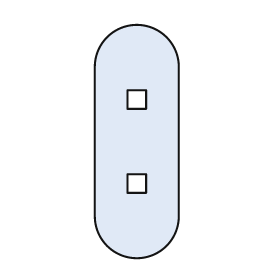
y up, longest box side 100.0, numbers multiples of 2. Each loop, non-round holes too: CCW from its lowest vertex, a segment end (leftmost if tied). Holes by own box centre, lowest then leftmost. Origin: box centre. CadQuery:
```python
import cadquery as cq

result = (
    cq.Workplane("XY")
    .moveTo(-18.0, -32.0)
    .threePointArc((0.0, -50.0), (18.0, -32.0))
    .lineTo(18.0, 32.0)
    .threePointArc((0.0, 50.0), (-18.0, 32.0))
    .close()
    .moveTo(-4.0, -22.0)
    .lineTo(4.0, -22.0)
    .lineTo(4.0, -14.0)
    .lineTo(-4.0, -14.0)
    .close()
    .moveTo(-4.0, 14.0)
    .lineTo(4.0, 14.0)
    .lineTo(4.0, 22.0)
    .lineTo(-4.0, 22.0)
    .close()
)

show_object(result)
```